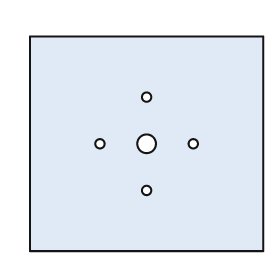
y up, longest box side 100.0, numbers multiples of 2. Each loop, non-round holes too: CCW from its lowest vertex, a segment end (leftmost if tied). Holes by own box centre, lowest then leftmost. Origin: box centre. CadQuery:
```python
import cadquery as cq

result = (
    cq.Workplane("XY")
    .moveTo(-50.0, -46.0)
    .lineTo(50.0, -46.0)
    .lineTo(50.0, 46.0)
    .lineTo(-50.0, 46.0)
    .close()
    .moveTo(0.0, -20.0)
    .circle(2.0)
    .moveTo(-20.0, 0.0)
    .circle(2.0)
    .moveTo(0.0, 0.0)
    .circle(4.0)
    .moveTo(20.0, 0.0)
    .circle(2.0)
    .moveTo(0.0, 20.0)
    .circle(2.0)
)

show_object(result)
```